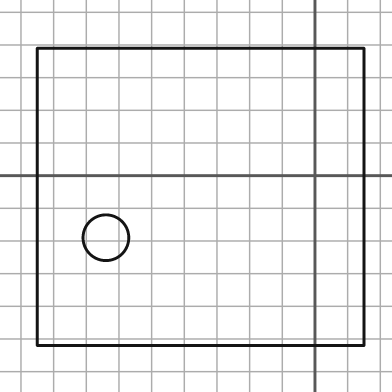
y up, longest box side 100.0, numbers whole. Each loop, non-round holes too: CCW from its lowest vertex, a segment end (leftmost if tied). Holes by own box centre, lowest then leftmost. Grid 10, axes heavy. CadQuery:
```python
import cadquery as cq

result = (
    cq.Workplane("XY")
    .moveTo(-85.0, -52.0)
    .lineTo(15.0, -52.0)
    .lineTo(15.0, 39.0)
    .lineTo(-85.0, 39.0)
    .close()
    .moveTo(-64.0, -19.0)
    .circle(7.0)
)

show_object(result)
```